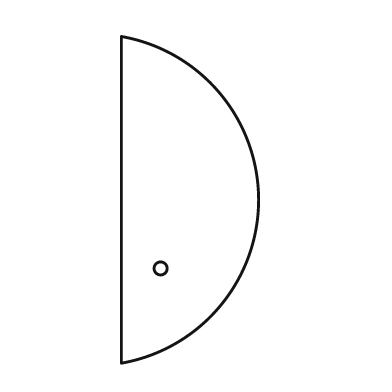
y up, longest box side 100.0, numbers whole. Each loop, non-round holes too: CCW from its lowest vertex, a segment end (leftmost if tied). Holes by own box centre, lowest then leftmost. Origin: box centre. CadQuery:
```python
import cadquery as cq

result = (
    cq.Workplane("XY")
    .moveTo(-21.0, -50.0)
    .threePointArc((21.0, 0.0), (-21.0, 50.0))
    .close()
    .moveTo(-9.0, -21.0)
    .circle(2.0)
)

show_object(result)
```